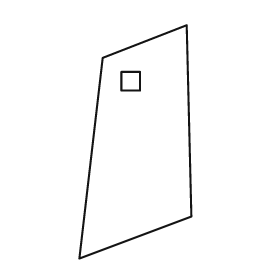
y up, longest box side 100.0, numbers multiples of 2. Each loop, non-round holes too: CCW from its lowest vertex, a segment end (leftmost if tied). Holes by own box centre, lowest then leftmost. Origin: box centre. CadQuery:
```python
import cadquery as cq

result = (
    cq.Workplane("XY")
    .moveTo(-24.0, -50.0)
    .lineTo(24.0, -32.0)
    .lineTo(22.0, 50.0)
    .lineTo(-14.0, 36.0)
    .close()
    .moveTo(-6.0, 22.0)
    .lineTo(2.0, 22.0)
    .lineTo(2.0, 30.0)
    .lineTo(-6.0, 30.0)
    .close()
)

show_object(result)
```